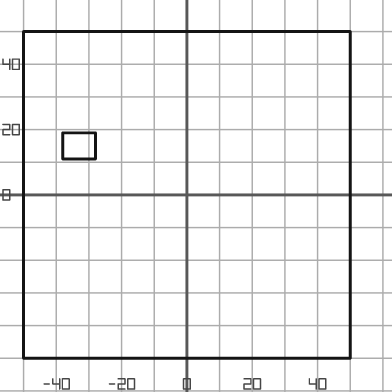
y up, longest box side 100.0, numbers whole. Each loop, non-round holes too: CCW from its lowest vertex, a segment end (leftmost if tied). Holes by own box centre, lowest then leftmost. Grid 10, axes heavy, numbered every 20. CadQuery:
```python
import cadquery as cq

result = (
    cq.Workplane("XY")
    .moveTo(-50.0, -50.0)
    .lineTo(50.0, -50.0)
    .lineTo(50.0, 50.0)
    .lineTo(-50.0, 50.0)
    .close()
    .moveTo(-38.0, 11.0)
    .lineTo(-28.0, 11.0)
    .lineTo(-28.0, 19.0)
    .lineTo(-38.0, 19.0)
    .close()
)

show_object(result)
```